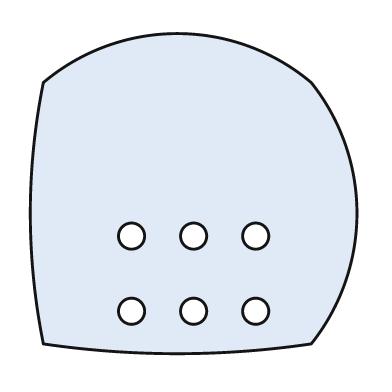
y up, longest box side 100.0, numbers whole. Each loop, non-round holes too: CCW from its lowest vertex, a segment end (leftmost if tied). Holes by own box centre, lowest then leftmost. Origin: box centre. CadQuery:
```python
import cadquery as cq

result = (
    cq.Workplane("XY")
    .moveTo(-46.0, -46.0)
    .threePointArc((-5.0, -49.0), (36.0, -46.0))
    .threePointArc((50.0, -6.0), (36.0, 34.0))
    .threePointArc((-5.0, 49.0), (-46.0, 34.0))
    .threePointArc((-50.0, -6.0), (-46.0, -46.0))
    .close()
    .moveTo(-19.0, -36.0)
    .circle(4.0)
    .moveTo(0.0, -36.0)
    .circle(4.0)
    .moveTo(19.0, -36.0)
    .circle(4.0)
    .moveTo(-19.0, -13.0)
    .circle(4.0)
    .moveTo(0.0, -13.0)
    .circle(4.0)
    .moveTo(19.0, -13.0)
    .circle(4.0)
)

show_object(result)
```